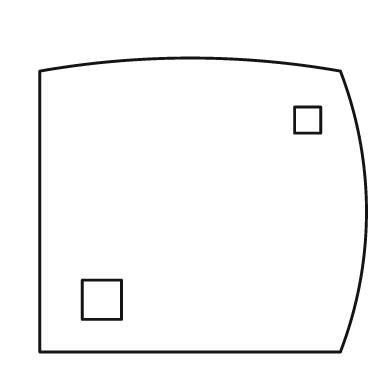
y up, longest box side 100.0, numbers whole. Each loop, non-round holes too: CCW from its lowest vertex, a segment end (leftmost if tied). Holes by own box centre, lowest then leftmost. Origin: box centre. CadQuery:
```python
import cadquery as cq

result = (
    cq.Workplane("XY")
    .moveTo(-50.0, -45.0)
    .lineTo(42.0, -45.0)
    .threePointArc((50.0, -2.0), (42.0, 41.0))
    .threePointArc((-4.0, 45.0), (-50.0, 41.0))
    .close()
    .moveTo(-37.0, -35.0)
    .lineTo(-25.0, -35.0)
    .lineTo(-25.0, -23.0)
    .lineTo(-37.0, -23.0)
    .close()
    .moveTo(28.0, 22.0)
    .lineTo(36.0, 22.0)
    .lineTo(36.0, 30.0)
    .lineTo(28.0, 30.0)
    .close()
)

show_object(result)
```